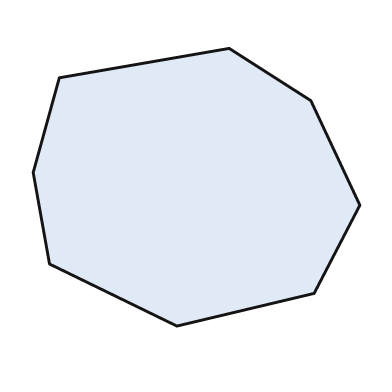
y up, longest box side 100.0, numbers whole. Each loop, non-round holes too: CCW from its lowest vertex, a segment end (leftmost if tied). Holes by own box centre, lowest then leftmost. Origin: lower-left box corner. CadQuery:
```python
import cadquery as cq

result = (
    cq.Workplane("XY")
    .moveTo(44.0, 0.0)
    .lineTo(86.0, 10.0)
    .lineTo(100.0, 37.0)
    .lineTo(85.0, 69.0)
    .lineTo(60.0, 85.0)
    .lineTo(8.0, 76.0)
    .lineTo(0.0, 47.0)
    .lineTo(5.0, 19.0)
    .close()
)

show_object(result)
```